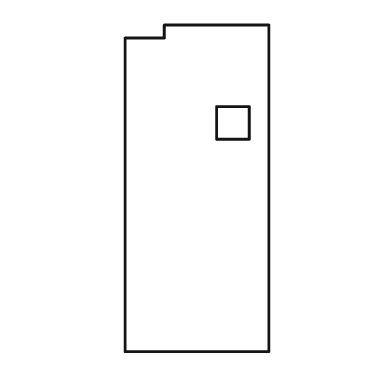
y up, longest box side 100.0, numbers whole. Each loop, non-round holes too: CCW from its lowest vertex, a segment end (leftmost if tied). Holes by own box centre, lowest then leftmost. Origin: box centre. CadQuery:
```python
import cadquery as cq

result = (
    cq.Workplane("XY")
    .moveTo(-22.0, -50.0)
    .lineTo(22.0, -50.0)
    .lineTo(22.0, 50.0)
    .lineTo(-10.0, 50.0)
    .lineTo(-10.0, 46.0)
    .lineTo(-22.0, 46.0)
    .close()
    .moveTo(6.0, 15.0)
    .lineTo(16.0, 15.0)
    .lineTo(16.0, 25.0)
    .lineTo(6.0, 25.0)
    .close()
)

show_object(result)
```